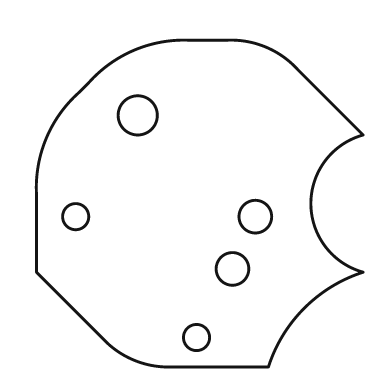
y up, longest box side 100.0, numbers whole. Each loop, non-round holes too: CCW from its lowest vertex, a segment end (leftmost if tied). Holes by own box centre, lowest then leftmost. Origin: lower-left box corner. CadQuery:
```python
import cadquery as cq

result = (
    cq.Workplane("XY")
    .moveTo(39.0, 0.0)
    .lineTo(71.0, 0.0)
    .threePointArc((82.0, 18.0), (100.0, 29.0))
    .threePointArc((84.0, 50.0), (100.0, 71.0))
    .lineTo(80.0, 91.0)
    .threePointArc((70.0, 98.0), (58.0, 100.0))
    .lineTo(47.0, 100.0)
    .threePointArc((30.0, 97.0), (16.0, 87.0))
    .lineTo(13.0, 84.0)
    .threePointArc((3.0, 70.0), (0.0, 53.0))
    .lineTo(0.0, 29.0)
    .lineTo(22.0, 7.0)
    .threePointArc((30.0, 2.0), (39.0, 0.0))
    .close()
    .moveTo(49.0, 9.0)
    .circle(4.0)
    .moveTo(60.0, 30.0)
    .circle(5.0)
    .moveTo(12.0, 46.0)
    .circle(4.0)
    .moveTo(67.0, 46.0)
    .circle(5.0)
    .moveTo(31.0, 77.0)
    .circle(6.0)
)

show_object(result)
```